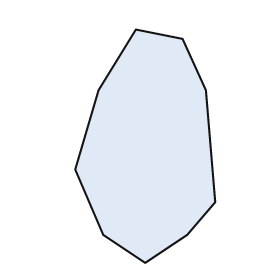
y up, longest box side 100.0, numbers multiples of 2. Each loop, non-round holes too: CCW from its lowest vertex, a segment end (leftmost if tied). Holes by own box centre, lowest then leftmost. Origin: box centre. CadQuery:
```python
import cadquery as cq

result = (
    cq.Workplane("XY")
    .moveTo(0.0, -50.0)
    .lineTo(18.0, -38.0)
    .lineTo(30.0, -24.0)
    .lineTo(26.0, 24.0)
    .lineTo(16.0, 46.0)
    .lineTo(-4.0, 50.0)
    .lineTo(-20.0, 24.0)
    .lineTo(-30.0, -10.0)
    .lineTo(-18.0, -38.0)
    .close()
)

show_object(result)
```